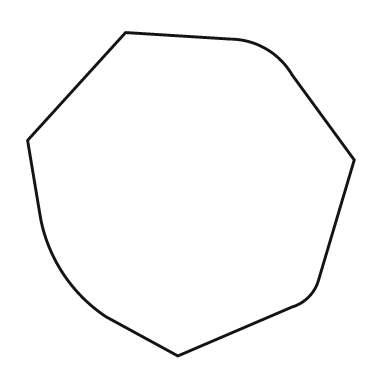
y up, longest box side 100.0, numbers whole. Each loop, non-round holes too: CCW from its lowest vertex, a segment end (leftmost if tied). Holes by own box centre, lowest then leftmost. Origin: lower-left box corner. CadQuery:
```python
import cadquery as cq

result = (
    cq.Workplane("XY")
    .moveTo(46.0, 0.0)
    .lineTo(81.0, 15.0)
    .threePointArc((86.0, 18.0), (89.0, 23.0))
    .lineTo(100.0, 60.0)
    .lineTo(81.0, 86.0)
    .threePointArc((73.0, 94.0), (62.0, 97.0))
    .lineTo(30.0, 99.0)
    .lineTo(0.0, 66.0)
    .lineTo(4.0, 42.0)
    .threePointArc((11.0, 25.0), (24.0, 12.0))
    .close()
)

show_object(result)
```